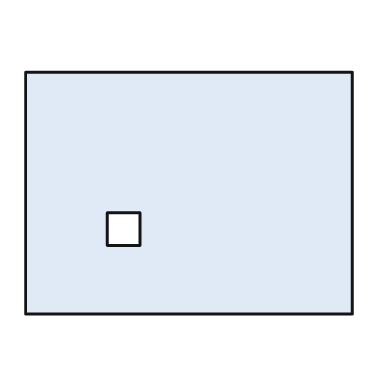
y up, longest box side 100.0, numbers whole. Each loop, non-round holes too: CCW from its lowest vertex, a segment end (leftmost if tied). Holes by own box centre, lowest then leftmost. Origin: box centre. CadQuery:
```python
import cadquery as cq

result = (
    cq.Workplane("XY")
    .moveTo(-50.0, -37.0)
    .lineTo(50.0, -37.0)
    .lineTo(50.0, 37.0)
    .lineTo(-50.0, 37.0)
    .close()
    .moveTo(-25.0, -16.0)
    .lineTo(-15.0, -16.0)
    .lineTo(-15.0, -6.0)
    .lineTo(-25.0, -6.0)
    .close()
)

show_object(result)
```